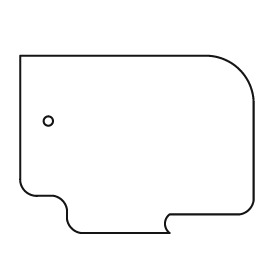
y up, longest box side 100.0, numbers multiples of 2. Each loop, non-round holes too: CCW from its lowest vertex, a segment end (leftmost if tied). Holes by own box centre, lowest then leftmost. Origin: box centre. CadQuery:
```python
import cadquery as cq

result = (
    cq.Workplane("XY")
    .moveTo(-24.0, -38.0)
    .lineTo(14.0, -38.0)
    .threePointArc((12.0, -34.0), (14.0, -30.0))
    .lineTo(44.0, -30.0)
    .threePointArc((48.0, -28.0), (50.0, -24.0))
    .lineTo(50.0, 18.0)
    .threePointArc((44.0, 32.0), (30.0, 38.0))
    .lineTo(-50.0, 38.0)
    .lineTo(-50.0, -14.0)
    .threePointArc((-48.0, -20.0), (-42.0, -22.0))
    .lineTo(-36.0, -22.0)
    .threePointArc((-32.0, -24.0), (-30.0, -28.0))
    .lineTo(-30.0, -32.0)
    .threePointArc((-28.0, -36.0), (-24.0, -38.0))
    .close()
    .moveTo(-38.0, 10.0)
    .circle(2.0)
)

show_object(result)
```